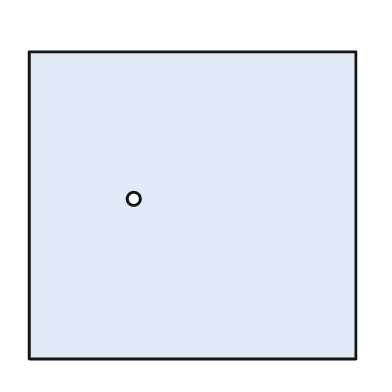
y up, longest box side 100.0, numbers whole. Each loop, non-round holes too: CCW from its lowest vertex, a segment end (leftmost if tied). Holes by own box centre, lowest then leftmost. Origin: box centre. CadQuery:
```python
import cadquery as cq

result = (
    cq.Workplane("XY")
    .moveTo(-50.0, -47.0)
    .lineTo(50.0, -47.0)
    .lineTo(50.0, 47.0)
    .lineTo(-50.0, 47.0)
    .close()
    .moveTo(-18.0, 2.0)
    .circle(2.0)
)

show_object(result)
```